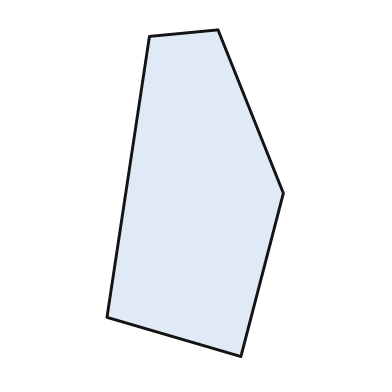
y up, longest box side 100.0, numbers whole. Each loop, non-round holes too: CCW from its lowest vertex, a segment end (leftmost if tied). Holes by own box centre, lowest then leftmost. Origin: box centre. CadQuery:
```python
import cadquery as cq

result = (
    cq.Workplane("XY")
    .moveTo(14.0, -50.0)
    .lineTo(27.0, 0.0)
    .lineTo(7.0, 50.0)
    .lineTo(-14.0, 48.0)
    .lineTo(-27.0, -38.0)
    .close()
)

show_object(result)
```